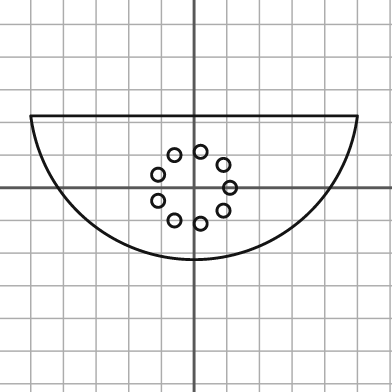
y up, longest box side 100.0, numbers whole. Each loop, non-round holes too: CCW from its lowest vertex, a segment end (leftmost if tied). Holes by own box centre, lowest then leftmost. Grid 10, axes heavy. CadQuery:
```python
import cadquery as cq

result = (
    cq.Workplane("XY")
    .moveTo(-50.0, 22.0)
    .threePointArc((0.0, -22.0), (50.0, 22.0))
    .close()
    .moveTo(2.0, -11.0)
    .circle(2.0)
    .moveTo(-6.0, -10.0)
    .circle(2.0)
    .moveTo(9.0, -7.0)
    .circle(2.0)
    .moveTo(-11.0, -4.0)
    .circle(2.0)
    .moveTo(11.0, 0.0)
    .circle(2.0)
    .moveTo(-11.0, 4.0)
    .circle(2.0)
    .moveTo(9.0, 7.0)
    .circle(2.0)
    .moveTo(-6.0, 10.0)
    .circle(2.0)
    .moveTo(2.0, 11.0)
    .circle(2.0)
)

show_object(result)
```